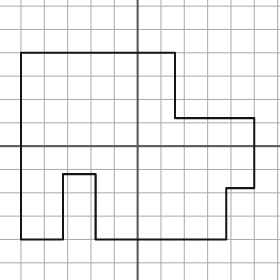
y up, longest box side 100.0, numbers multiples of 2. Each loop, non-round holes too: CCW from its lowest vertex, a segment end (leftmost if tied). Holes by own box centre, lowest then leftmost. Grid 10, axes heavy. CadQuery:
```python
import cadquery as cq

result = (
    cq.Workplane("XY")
    .moveTo(-50.0, -40.0)
    .lineTo(-32.0, -40.0)
    .lineTo(-32.0, -12.0)
    .lineTo(-18.0, -12.0)
    .lineTo(-18.0, -40.0)
    .lineTo(38.0, -40.0)
    .lineTo(38.0, -18.0)
    .lineTo(50.0, -18.0)
    .lineTo(50.0, 12.0)
    .lineTo(16.0, 12.0)
    .lineTo(16.0, 40.0)
    .lineTo(-50.0, 40.0)
    .close()
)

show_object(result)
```